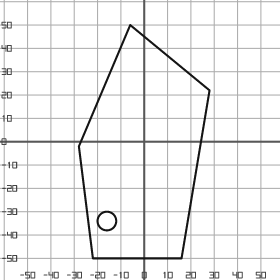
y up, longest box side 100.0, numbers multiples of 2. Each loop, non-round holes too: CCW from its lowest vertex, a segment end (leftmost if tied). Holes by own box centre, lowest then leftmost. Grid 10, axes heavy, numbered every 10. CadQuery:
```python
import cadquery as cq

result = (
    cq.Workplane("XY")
    .moveTo(-22.0, -50.0)
    .lineTo(16.0, -50.0)
    .lineTo(28.0, 22.0)
    .lineTo(-6.0, 50.0)
    .lineTo(-28.0, -2.0)
    .close()
    .moveTo(-16.0, -34.0)
    .circle(4.0)
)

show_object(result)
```